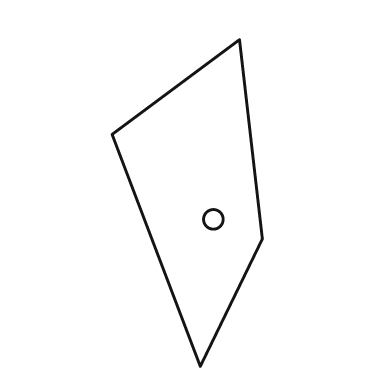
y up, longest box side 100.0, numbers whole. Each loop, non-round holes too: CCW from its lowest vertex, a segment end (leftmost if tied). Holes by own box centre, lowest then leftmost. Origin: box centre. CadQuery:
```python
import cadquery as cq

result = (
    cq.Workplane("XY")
    .moveTo(4.0, -50.0)
    .lineTo(23.0, -11.0)
    .lineTo(16.0, 50.0)
    .lineTo(-23.0, 21.0)
    .close()
    .moveTo(8.0, -5.0)
    .circle(3.0)
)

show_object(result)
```